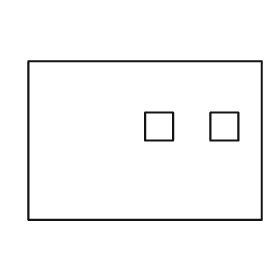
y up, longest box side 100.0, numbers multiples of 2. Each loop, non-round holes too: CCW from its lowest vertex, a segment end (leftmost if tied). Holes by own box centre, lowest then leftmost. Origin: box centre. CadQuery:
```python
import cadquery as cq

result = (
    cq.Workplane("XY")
    .moveTo(-50.0, -34.0)
    .lineTo(50.0, -34.0)
    .lineTo(50.0, 34.0)
    .lineTo(-50.0, 34.0)
    .close()
    .moveTo(0.0, 0.0)
    .lineTo(12.0, 0.0)
    .lineTo(12.0, 12.0)
    .lineTo(0.0, 12.0)
    .close()
    .moveTo(28.0, 0.0)
    .lineTo(40.0, 0.0)
    .lineTo(40.0, 12.0)
    .lineTo(28.0, 12.0)
    .close()
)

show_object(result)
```